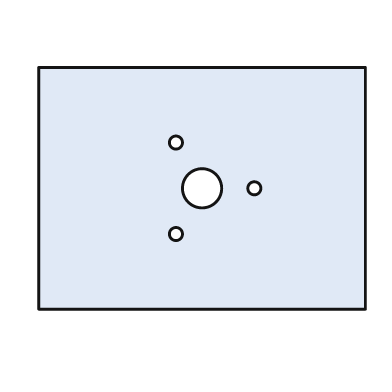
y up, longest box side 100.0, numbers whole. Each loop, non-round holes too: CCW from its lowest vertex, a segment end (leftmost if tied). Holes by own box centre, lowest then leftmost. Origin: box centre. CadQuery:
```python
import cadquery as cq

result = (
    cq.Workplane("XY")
    .moveTo(-50.0, -37.0)
    .lineTo(50.0, -37.0)
    .lineTo(50.0, 37.0)
    .lineTo(-50.0, 37.0)
    .close()
    .moveTo(-8.0, -14.0)
    .circle(2.0)
    .moveTo(0.0, 0.0)
    .circle(6.0)
    .moveTo(16.0, 0.0)
    .circle(2.0)
    .moveTo(-8.0, 14.0)
    .circle(2.0)
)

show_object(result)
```